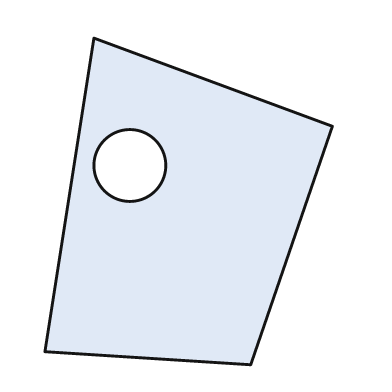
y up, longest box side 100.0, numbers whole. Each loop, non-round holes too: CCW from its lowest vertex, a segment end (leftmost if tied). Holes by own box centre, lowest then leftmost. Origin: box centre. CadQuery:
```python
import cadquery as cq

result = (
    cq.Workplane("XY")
    .moveTo(19.0, -50.0)
    .lineTo(44.0, 23.0)
    .lineTo(-29.0, 50.0)
    .lineTo(-44.0, -46.0)
    .close()
    .moveTo(-18.0, 11.0)
    .circle(11.0)
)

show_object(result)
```